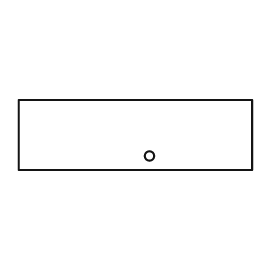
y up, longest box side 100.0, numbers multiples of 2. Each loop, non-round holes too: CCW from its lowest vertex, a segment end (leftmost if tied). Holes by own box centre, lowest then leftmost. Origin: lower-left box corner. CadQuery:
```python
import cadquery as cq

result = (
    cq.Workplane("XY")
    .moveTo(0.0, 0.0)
    .lineTo(100.0, 0.0)
    .lineTo(100.0, 30.0)
    .lineTo(0.0, 30.0)
    .close()
    .moveTo(56.0, 6.0)
    .circle(2.0)
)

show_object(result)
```